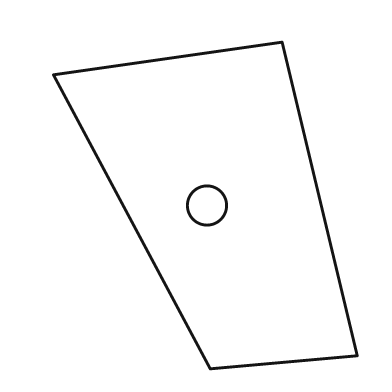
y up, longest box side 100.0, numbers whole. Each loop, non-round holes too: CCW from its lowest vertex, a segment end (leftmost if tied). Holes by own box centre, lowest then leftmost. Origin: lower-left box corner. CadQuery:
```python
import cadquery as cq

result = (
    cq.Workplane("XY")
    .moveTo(48.0, 0.0)
    .lineTo(93.0, 4.0)
    .lineTo(70.0, 100.0)
    .lineTo(0.0, 90.0)
    .close()
    .moveTo(47.0, 50.0)
    .circle(6.0)
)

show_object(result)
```